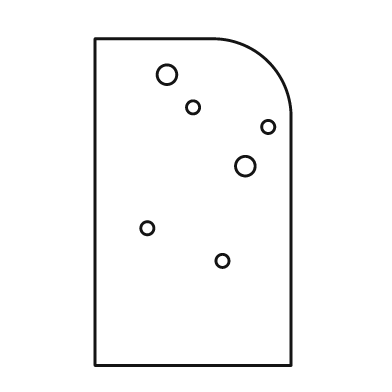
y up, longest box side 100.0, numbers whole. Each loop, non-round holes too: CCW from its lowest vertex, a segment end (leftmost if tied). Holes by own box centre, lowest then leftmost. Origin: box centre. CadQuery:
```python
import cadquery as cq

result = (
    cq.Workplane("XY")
    .moveTo(-30.0, -50.0)
    .lineTo(30.0, -50.0)
    .lineTo(30.0, 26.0)
    .threePointArc((23.0, 43.0), (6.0, 50.0))
    .lineTo(-30.0, 50.0)
    .close()
    .moveTo(9.0, -18.0)
    .circle(2.0)
    .moveTo(-14.0, -8.0)
    .circle(2.0)
    .moveTo(16.0, 11.0)
    .circle(3.0)
    .moveTo(23.0, 23.0)
    .circle(2.0)
    .moveTo(0.0, 29.0)
    .circle(2.0)
    .moveTo(-8.0, 39.0)
    .circle(3.0)
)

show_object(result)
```